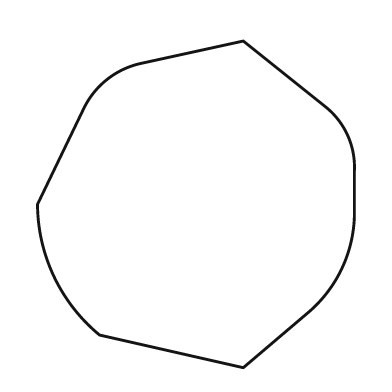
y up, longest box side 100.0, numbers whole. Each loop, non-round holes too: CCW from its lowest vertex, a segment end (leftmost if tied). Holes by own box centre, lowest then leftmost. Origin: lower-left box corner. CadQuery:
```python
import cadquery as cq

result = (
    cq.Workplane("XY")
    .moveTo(63.0, 0.0)
    .lineTo(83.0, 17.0)
    .threePointArc((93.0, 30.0), (97.0, 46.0))
    .lineTo(97.0, 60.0)
    .threePointArc((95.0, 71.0), (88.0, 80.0))
    .lineTo(63.0, 100.0)
    .lineTo(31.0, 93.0)
    .threePointArc((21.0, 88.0), (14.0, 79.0))
    .lineTo(0.0, 50.0)
    .threePointArc((5.0, 28.0), (19.0, 10.0))
    .close()
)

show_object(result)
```